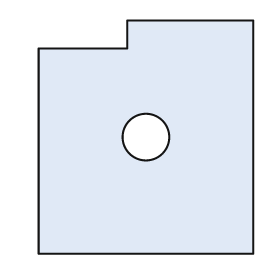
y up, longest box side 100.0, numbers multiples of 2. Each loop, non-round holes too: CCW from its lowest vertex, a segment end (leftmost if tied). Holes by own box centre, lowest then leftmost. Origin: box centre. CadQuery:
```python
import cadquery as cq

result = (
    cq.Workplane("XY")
    .moveTo(-46.0, -50.0)
    .lineTo(46.0, -50.0)
    .lineTo(46.0, 50.0)
    .lineTo(-8.0, 50.0)
    .lineTo(-8.0, 38.0)
    .lineTo(-46.0, 38.0)
    .close()
    .moveTo(0.0, 0.0)
    .circle(10.0)
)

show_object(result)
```